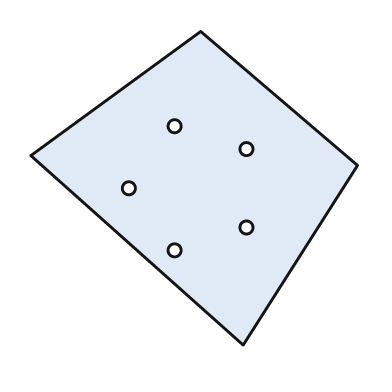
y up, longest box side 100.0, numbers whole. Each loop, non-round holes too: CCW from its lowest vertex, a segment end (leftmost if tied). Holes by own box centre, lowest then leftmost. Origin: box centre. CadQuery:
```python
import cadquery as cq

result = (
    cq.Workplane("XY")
    .moveTo(15.0, -48.0)
    .lineTo(50.0, 7.0)
    .lineTo(2.0, 48.0)
    .lineTo(-50.0, 10.0)
    .close()
    .moveTo(-6.0, -19.0)
    .circle(2.0)
    .moveTo(16.0, -12.0)
    .circle(2.0)
    .moveTo(-20.0, 0.0)
    .circle(2.0)
    .moveTo(16.0, 12.0)
    .circle(2.0)
    .moveTo(-6.0, 19.0)
    .circle(2.0)
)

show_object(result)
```